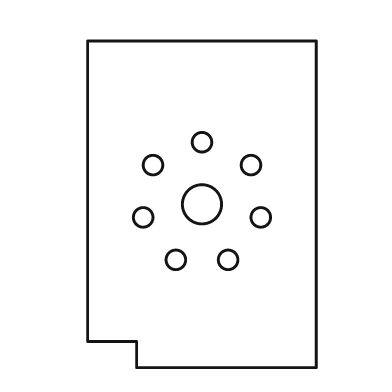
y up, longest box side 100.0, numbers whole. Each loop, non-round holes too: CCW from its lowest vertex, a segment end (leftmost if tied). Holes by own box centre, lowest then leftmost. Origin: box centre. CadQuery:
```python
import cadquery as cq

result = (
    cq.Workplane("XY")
    .moveTo(-20.0, -50.0)
    .lineTo(35.0, -50.0)
    .lineTo(35.0, 50.0)
    .lineTo(-35.0, 50.0)
    .lineTo(-35.0, -42.0)
    .lineTo(-20.0, -42.0)
    .close()
    .moveTo(-8.0, -17.0)
    .circle(3.0)
    .moveTo(8.0, -17.0)
    .circle(3.0)
    .moveTo(-18.0, -4.0)
    .circle(3.0)
    .moveTo(18.0, -4.0)
    .circle(3.0)
    .moveTo(0.0, 0.0)
    .circle(6.0)
    .moveTo(-15.0, 12.0)
    .circle(3.0)
    .moveTo(15.0, 12.0)
    .circle(3.0)
    .moveTo(0.0, 19.0)
    .circle(3.0)
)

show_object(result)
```